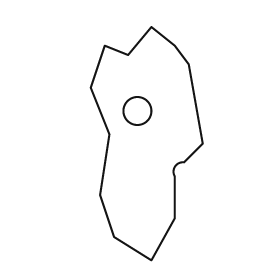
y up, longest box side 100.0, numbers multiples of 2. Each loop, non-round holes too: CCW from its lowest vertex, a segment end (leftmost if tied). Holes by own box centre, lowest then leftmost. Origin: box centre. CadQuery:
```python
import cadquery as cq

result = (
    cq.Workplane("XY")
    .moveTo(2.0, -50.0)
    .lineTo(12.0, -32.0)
    .lineTo(12.0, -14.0)
    .threePointArc((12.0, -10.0), (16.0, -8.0))
    .lineTo(24.0, 0.0)
    .lineTo(18.0, 34.0)
    .lineTo(12.0, 42.0)
    .lineTo(2.0, 50.0)
    .lineTo(-8.0, 38.0)
    .lineTo(-18.0, 42.0)
    .lineTo(-24.0, 24.0)
    .lineTo(-16.0, 4.0)
    .lineTo(-20.0, -22.0)
    .lineTo(-14.0, -40.0)
    .close()
    .moveTo(-4.0, 14.0)
    .circle(6.0)
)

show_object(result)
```